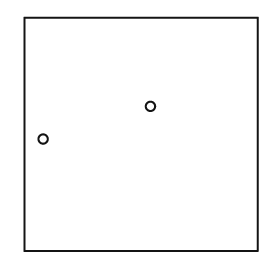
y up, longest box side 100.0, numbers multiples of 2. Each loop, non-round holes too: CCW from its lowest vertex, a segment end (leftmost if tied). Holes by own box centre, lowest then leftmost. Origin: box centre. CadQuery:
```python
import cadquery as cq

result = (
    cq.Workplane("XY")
    .moveTo(-50.0, -50.0)
    .lineTo(50.0, -50.0)
    .lineTo(50.0, 50.0)
    .lineTo(-50.0, 50.0)
    .close()
    .moveTo(-42.0, -2.0)
    .circle(2.0)
    .moveTo(4.0, 12.0)
    .circle(2.0)
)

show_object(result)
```